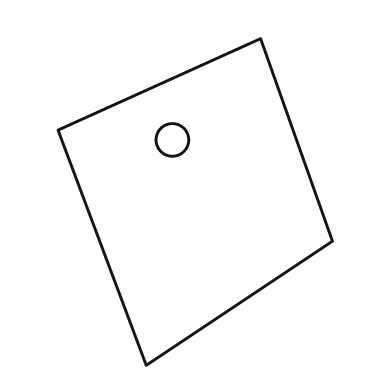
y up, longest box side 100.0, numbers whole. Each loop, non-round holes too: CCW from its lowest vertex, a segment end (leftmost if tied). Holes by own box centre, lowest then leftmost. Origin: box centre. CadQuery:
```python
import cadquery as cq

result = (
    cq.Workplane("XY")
    .moveTo(-15.0, -50.0)
    .lineTo(42.0, -12.0)
    .lineTo(20.0, 50.0)
    .lineTo(-42.0, 22.0)
    .close()
    .moveTo(-7.0, 19.0)
    .circle(5.0)
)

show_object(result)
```